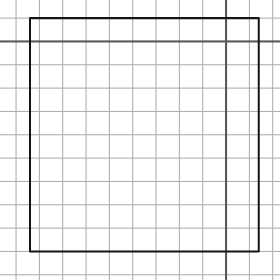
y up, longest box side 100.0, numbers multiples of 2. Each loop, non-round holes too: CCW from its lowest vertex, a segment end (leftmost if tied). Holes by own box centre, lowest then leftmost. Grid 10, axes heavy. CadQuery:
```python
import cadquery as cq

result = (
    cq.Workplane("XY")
    .moveTo(-84.0, -90.0)
    .lineTo(14.0, -90.0)
    .lineTo(14.0, 10.0)
    .lineTo(-84.0, 10.0)
    .close()
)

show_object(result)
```